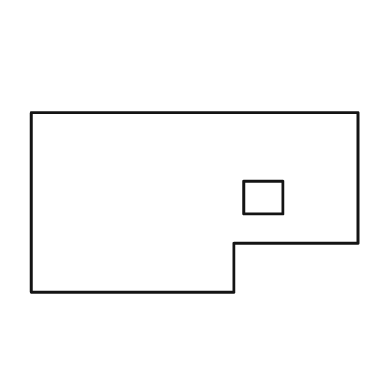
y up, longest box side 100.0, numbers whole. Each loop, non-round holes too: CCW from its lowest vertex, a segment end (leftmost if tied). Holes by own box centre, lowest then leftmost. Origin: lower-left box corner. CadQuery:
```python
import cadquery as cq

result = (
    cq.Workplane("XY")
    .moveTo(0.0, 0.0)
    .lineTo(62.0, 0.0)
    .lineTo(62.0, 15.0)
    .lineTo(100.0, 15.0)
    .lineTo(100.0, 55.0)
    .lineTo(0.0, 55.0)
    .close()
    .moveTo(65.0, 24.0)
    .lineTo(77.0, 24.0)
    .lineTo(77.0, 34.0)
    .lineTo(65.0, 34.0)
    .close()
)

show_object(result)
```